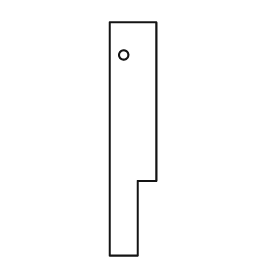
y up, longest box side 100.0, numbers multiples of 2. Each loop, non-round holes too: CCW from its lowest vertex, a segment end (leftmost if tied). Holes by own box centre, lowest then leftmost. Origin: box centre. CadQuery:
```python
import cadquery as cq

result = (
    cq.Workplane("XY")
    .moveTo(-10.0, -50.0)
    .lineTo(2.0, -50.0)
    .lineTo(2.0, -18.0)
    .lineTo(10.0, -18.0)
    .lineTo(10.0, 50.0)
    .lineTo(-10.0, 50.0)
    .close()
    .moveTo(-4.0, 36.0)
    .circle(2.0)
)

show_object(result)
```